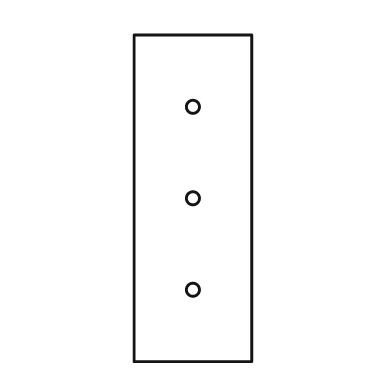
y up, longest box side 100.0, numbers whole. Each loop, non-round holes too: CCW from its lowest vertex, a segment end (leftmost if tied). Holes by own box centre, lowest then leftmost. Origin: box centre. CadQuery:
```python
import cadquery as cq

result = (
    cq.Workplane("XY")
    .moveTo(-18.0, -50.0)
    .lineTo(18.0, -50.0)
    .lineTo(18.0, 50.0)
    .lineTo(-18.0, 50.0)
    .close()
    .moveTo(0.0, -28.0)
    .circle(2.0)
    .moveTo(0.0, 0.0)
    .circle(2.0)
    .moveTo(0.0, 28.0)
    .circle(2.0)
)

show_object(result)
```